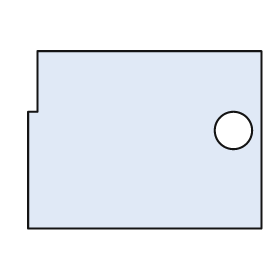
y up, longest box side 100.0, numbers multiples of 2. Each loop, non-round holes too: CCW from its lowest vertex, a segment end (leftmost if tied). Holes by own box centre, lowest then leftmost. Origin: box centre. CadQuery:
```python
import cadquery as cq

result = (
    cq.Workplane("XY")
    .moveTo(-50.0, -38.0)
    .lineTo(50.0, -38.0)
    .lineTo(50.0, 38.0)
    .lineTo(-46.0, 38.0)
    .lineTo(-46.0, 12.0)
    .lineTo(-50.0, 12.0)
    .close()
    .moveTo(38.0, 4.0)
    .circle(8.0)
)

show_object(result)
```